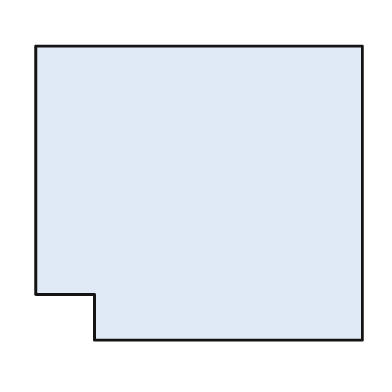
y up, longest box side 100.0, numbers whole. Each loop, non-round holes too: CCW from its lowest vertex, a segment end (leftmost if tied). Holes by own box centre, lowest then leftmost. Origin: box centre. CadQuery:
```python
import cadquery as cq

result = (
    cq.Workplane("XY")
    .moveTo(-32.0, -45.0)
    .lineTo(50.0, -45.0)
    .lineTo(50.0, 45.0)
    .lineTo(-50.0, 45.0)
    .lineTo(-50.0, -31.0)
    .lineTo(-32.0, -31.0)
    .close()
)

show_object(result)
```